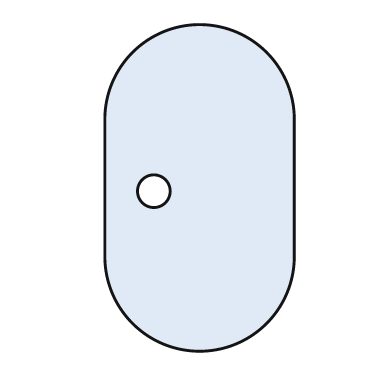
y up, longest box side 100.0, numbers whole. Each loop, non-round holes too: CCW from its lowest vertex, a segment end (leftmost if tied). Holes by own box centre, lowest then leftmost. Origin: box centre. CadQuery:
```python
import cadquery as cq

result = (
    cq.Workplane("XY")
    .moveTo(-29.0, -21.0)
    .threePointArc((0.0, -50.0), (29.0, -21.0))
    .lineTo(29.0, 21.0)
    .threePointArc((0.0, 50.0), (-29.0, 21.0))
    .close()
    .moveTo(-14.0, -1.0)
    .circle(5.0)
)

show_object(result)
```